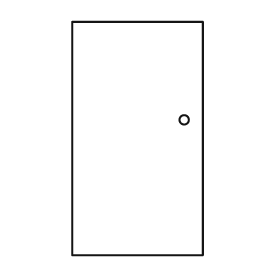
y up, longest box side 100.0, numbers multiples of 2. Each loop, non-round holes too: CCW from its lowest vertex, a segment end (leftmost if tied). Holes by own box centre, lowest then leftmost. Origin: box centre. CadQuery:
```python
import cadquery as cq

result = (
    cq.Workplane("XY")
    .moveTo(-28.0, -50.0)
    .lineTo(28.0, -50.0)
    .lineTo(28.0, 50.0)
    .lineTo(-28.0, 50.0)
    .close()
    .moveTo(20.0, 8.0)
    .circle(2.0)
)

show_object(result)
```